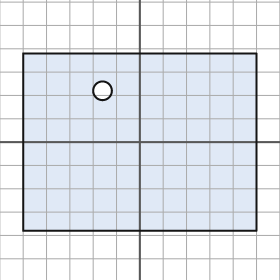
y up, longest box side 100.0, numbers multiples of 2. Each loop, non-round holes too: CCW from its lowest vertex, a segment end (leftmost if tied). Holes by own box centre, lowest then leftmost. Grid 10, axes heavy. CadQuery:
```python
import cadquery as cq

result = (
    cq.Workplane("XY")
    .moveTo(-50.0, -38.0)
    .lineTo(50.0, -38.0)
    .lineTo(50.0, 38.0)
    .lineTo(-50.0, 38.0)
    .close()
    .moveTo(-16.0, 22.0)
    .circle(4.0)
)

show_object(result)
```